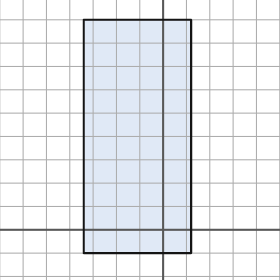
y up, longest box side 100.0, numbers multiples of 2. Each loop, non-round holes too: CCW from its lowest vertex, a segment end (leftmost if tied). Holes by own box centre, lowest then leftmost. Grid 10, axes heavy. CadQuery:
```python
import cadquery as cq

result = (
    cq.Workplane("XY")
    .moveTo(-34.0, -10.0)
    .lineTo(12.0, -10.0)
    .lineTo(12.0, 90.0)
    .lineTo(-34.0, 90.0)
    .close()
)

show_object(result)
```